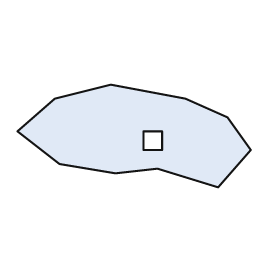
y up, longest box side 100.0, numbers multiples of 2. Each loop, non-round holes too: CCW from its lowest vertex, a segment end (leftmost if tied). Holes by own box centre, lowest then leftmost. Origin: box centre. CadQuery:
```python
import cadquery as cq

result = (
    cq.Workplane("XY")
    .moveTo(36.0, -22.0)
    .lineTo(50.0, -6.0)
    .lineTo(40.0, 8.0)
    .lineTo(22.0, 16.0)
    .lineTo(-10.0, 22.0)
    .lineTo(-34.0, 16.0)
    .lineTo(-50.0, 2.0)
    .lineTo(-32.0, -12.0)
    .lineTo(-8.0, -16.0)
    .lineTo(10.0, -14.0)
    .close()
    .moveTo(4.0, -6.0)
    .lineTo(12.0, -6.0)
    .lineTo(12.0, 2.0)
    .lineTo(4.0, 2.0)
    .close()
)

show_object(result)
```